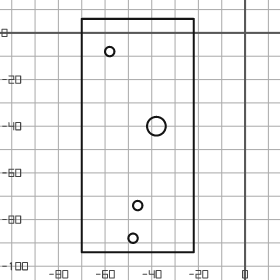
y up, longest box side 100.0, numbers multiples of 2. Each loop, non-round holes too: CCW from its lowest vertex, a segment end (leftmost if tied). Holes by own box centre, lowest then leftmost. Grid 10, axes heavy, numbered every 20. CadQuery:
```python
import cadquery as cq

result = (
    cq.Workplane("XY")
    .moveTo(-70.0, -94.0)
    .lineTo(-22.0, -94.0)
    .lineTo(-22.0, 6.0)
    .lineTo(-70.0, 6.0)
    .close()
    .moveTo(-48.0, -88.0)
    .circle(2.0)
    .moveTo(-46.0, -74.0)
    .circle(2.0)
    .moveTo(-38.0, -40.0)
    .circle(4.0)
    .moveTo(-58.0, -8.0)
    .circle(2.0)
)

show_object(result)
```